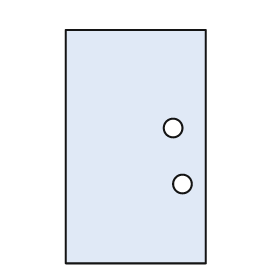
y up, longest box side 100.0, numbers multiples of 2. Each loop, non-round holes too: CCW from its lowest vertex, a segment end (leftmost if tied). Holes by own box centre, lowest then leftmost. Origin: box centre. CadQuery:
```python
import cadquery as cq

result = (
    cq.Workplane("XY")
    .moveTo(-30.0, -50.0)
    .lineTo(30.0, -50.0)
    .lineTo(30.0, 50.0)
    .lineTo(-30.0, 50.0)
    .close()
    .moveTo(20.0, -16.0)
    .circle(4.0)
    .moveTo(16.0, 8.0)
    .circle(4.0)
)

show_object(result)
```